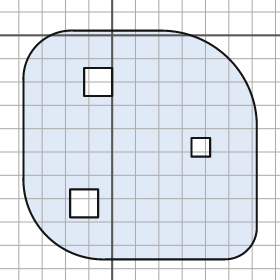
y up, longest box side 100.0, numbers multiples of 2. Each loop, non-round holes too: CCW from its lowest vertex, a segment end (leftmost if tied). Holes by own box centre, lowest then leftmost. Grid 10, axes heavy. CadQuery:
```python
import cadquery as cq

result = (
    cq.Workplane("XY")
    .moveTo(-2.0, -96.0)
    .lineTo(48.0, -96.0)
    .threePointArc((58.0, -92.0), (62.0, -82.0))
    .lineTo(62.0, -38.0)
    .threePointArc((50.0, -10.0), (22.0, 2.0))
    .lineTo(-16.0, 2.0)
    .threePointArc((-32.0, -4.0), (-38.0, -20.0))
    .lineTo(-38.0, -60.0)
    .threePointArc((-28.0, -86.0), (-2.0, -96.0))
    .close()
    .moveTo(-18.0, -78.0)
    .lineTo(-6.0, -78.0)
    .lineTo(-6.0, -66.0)
    .lineTo(-18.0, -66.0)
    .close()
    .moveTo(34.0, -52.0)
    .lineTo(42.0, -52.0)
    .lineTo(42.0, -44.0)
    .lineTo(34.0, -44.0)
    .close()
    .moveTo(-12.0, -26.0)
    .lineTo(0.0, -26.0)
    .lineTo(0.0, -14.0)
    .lineTo(-12.0, -14.0)
    .close()
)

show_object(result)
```